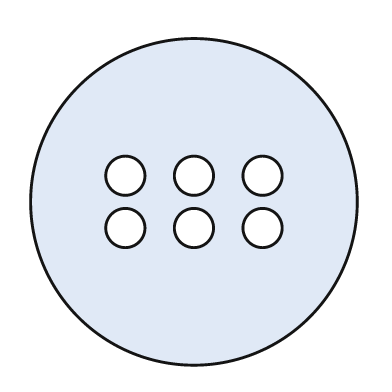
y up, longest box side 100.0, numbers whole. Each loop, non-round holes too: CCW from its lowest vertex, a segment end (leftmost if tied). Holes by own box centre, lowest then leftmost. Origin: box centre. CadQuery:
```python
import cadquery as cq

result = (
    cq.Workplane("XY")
    .moveTo(0.0, 0.0)
    .circle(50.0)
    .moveTo(-21.0, -8.0)
    .circle(6.0)
    .moveTo(0.0, -8.0)
    .circle(6.0)
    .moveTo(21.0, -8.0)
    .circle(6.0)
    .moveTo(-21.0, 8.0)
    .circle(6.0)
    .moveTo(0.0, 8.0)
    .circle(6.0)
    .moveTo(21.0, 8.0)
    .circle(6.0)
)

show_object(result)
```